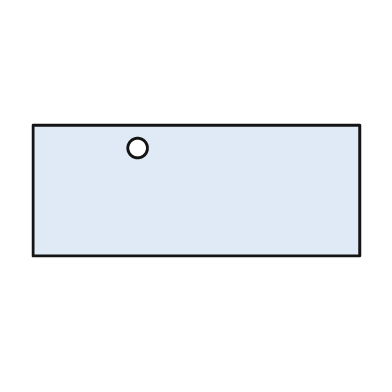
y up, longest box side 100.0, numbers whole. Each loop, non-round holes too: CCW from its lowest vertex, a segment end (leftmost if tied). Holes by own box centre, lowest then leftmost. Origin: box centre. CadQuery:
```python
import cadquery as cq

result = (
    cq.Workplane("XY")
    .moveTo(-50.0, -20.0)
    .lineTo(50.0, -20.0)
    .lineTo(50.0, 20.0)
    .lineTo(-50.0, 20.0)
    .close()
    .moveTo(-18.0, 13.0)
    .circle(3.0)
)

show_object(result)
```